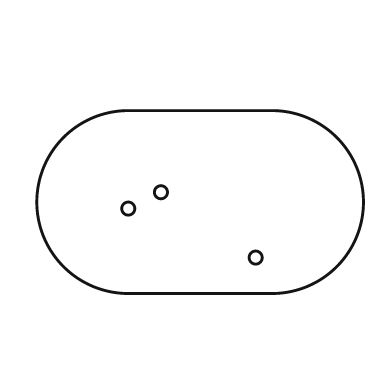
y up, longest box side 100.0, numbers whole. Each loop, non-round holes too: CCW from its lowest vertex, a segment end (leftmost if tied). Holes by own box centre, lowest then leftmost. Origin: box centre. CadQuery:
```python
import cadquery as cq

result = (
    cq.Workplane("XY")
    .moveTo(-22.0, -28.0)
    .lineTo(22.0, -28.0)
    .threePointArc((50.0, 0.0), (22.0, 28.0))
    .lineTo(-22.0, 28.0)
    .threePointArc((-50.0, 0.0), (-22.0, -28.0))
    .close()
    .moveTo(17.0, -17.0)
    .circle(2.0)
    .moveTo(-22.0, -2.0)
    .circle(2.0)
    .moveTo(-12.0, 3.0)
    .circle(2.0)
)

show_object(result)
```